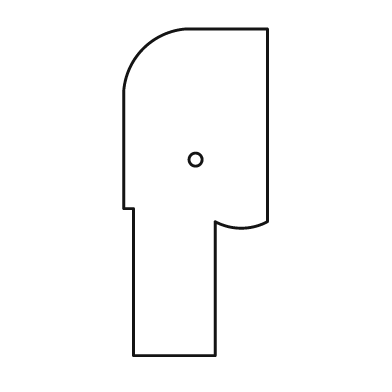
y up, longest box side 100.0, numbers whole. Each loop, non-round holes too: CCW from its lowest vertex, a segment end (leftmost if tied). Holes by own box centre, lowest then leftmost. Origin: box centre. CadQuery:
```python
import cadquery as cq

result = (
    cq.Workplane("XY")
    .moveTo(-19.0, -50.0)
    .lineTo(6.0, -50.0)
    .lineTo(6.0, -9.0)
    .threePointArc((14.0, -11.0), (22.0, -9.0))
    .lineTo(22.0, 50.0)
    .lineTo(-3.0, 50.0)
    .threePointArc((-16.0, 44.0), (-22.0, 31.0))
    .lineTo(-22.0, -5.0)
    .lineTo(-19.0, -5.0)
    .close()
    .moveTo(0.0, 10.0)
    .circle(2.0)
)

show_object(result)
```